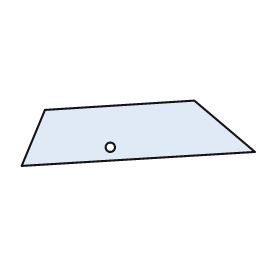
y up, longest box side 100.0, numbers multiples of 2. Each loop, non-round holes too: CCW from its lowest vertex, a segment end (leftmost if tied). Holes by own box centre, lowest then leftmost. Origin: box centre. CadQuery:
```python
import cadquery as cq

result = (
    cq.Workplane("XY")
    .moveTo(-50.0, -14.0)
    .lineTo(50.0, -8.0)
    .lineTo(24.0, 14.0)
    .lineTo(-40.0, 10.0)
    .close()
    .moveTo(-12.0, -6.0)
    .circle(2.0)
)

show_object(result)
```